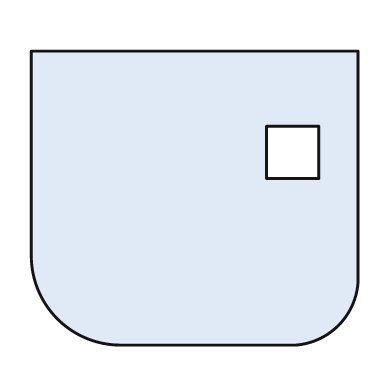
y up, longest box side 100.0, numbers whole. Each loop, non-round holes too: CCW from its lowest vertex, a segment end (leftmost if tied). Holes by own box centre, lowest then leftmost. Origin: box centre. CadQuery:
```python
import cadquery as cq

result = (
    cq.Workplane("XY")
    .moveTo(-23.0, -45.0)
    .lineTo(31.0, -45.0)
    .threePointArc((44.0, -39.0), (50.0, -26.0))
    .lineTo(50.0, 45.0)
    .lineTo(-50.0, 45.0)
    .lineTo(-50.0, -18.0)
    .threePointArc((-42.0, -37.0), (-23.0, -45.0))
    .close()
    .moveTo(22.0, 6.0)
    .lineTo(38.0, 6.0)
    .lineTo(38.0, 22.0)
    .lineTo(22.0, 22.0)
    .close()
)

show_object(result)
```